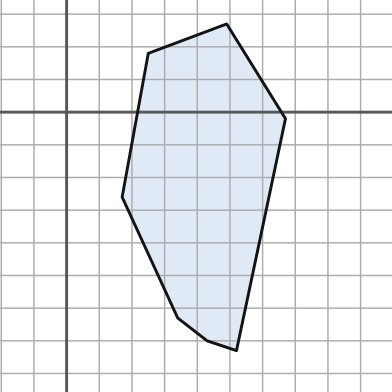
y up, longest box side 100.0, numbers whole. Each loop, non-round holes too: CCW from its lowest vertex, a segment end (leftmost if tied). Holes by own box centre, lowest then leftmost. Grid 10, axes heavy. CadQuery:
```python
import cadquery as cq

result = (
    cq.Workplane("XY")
    .moveTo(52.0, -73.0)
    .lineTo(67.0, -2.0)
    .lineTo(49.0, 27.0)
    .lineTo(25.0, 18.0)
    .lineTo(17.0, -26.0)
    .lineTo(34.0, -63.0)
    .lineTo(43.0, -70.0)
    .close()
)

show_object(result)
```